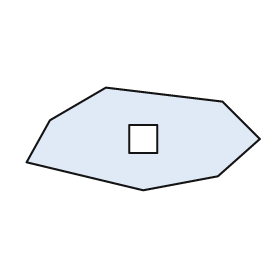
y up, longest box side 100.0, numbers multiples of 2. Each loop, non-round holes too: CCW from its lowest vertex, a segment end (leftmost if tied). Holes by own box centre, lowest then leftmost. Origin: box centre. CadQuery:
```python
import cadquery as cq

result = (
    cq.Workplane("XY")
    .moveTo(0.0, -22.0)
    .lineTo(32.0, -16.0)
    .lineTo(50.0, 0.0)
    .lineTo(34.0, 16.0)
    .lineTo(-16.0, 22.0)
    .lineTo(-40.0, 8.0)
    .lineTo(-50.0, -10.0)
    .close()
    .moveTo(-6.0, -6.0)
    .lineTo(6.0, -6.0)
    .lineTo(6.0, 6.0)
    .lineTo(-6.0, 6.0)
    .close()
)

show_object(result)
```